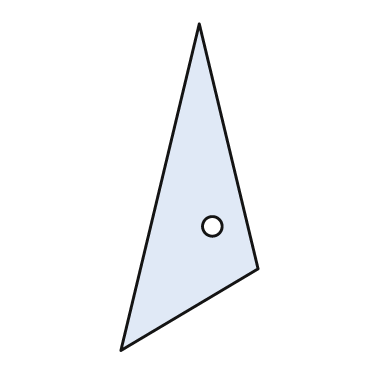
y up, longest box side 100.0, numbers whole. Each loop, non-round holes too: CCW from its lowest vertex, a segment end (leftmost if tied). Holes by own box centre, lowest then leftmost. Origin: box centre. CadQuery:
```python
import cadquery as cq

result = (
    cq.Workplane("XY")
    .moveTo(-21.0, -50.0)
    .lineTo(21.0, -25.0)
    .lineTo(3.0, 50.0)
    .close()
    .moveTo(7.0, -12.0)
    .circle(3.0)
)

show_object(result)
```